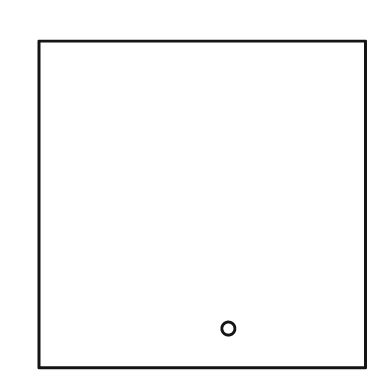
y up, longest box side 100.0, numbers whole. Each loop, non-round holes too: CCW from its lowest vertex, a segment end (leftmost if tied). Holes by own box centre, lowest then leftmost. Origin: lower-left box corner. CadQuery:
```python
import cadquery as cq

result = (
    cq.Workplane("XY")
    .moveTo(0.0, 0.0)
    .lineTo(100.0, 0.0)
    .lineTo(100.0, 100.0)
    .lineTo(0.0, 100.0)
    .close()
    .moveTo(58.0, 12.0)
    .circle(2.0)
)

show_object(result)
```